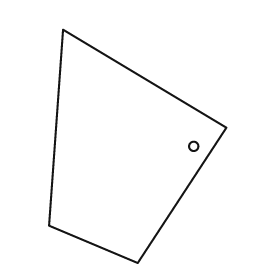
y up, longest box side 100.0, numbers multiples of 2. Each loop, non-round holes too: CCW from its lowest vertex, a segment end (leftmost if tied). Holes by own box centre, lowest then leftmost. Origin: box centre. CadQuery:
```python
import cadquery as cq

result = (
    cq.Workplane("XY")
    .moveTo(0.0, -50.0)
    .lineTo(38.0, 8.0)
    .lineTo(-32.0, 50.0)
    .lineTo(-38.0, -34.0)
    .close()
    .moveTo(24.0, 0.0)
    .circle(2.0)
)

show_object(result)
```